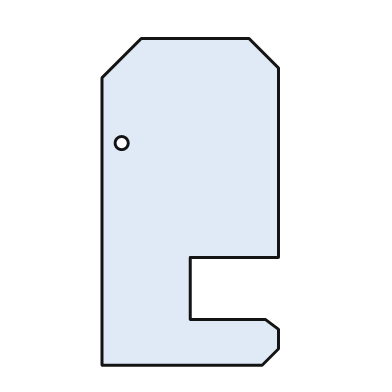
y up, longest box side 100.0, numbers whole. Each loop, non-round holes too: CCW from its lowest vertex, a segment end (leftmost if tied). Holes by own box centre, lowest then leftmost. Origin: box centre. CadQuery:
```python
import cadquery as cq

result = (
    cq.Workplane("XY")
    .moveTo(-27.0, -50.0)
    .lineTo(22.0, -50.0)
    .lineTo(27.0, -45.0)
    .lineTo(27.0, -39.0)
    .lineTo(23.0, -36.0)
    .lineTo(0.0, -36.0)
    .lineTo(0.0, -17.0)
    .lineTo(27.0, -17.0)
    .lineTo(27.0, 41.0)
    .lineTo(18.0, 50.0)
    .lineTo(-15.0, 50.0)
    .lineTo(-27.0, 38.0)
    .close()
    .moveTo(-21.0, 18.0)
    .circle(2.0)
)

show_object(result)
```